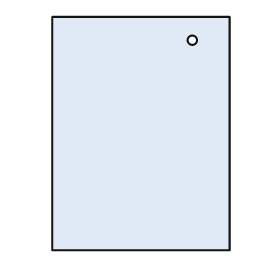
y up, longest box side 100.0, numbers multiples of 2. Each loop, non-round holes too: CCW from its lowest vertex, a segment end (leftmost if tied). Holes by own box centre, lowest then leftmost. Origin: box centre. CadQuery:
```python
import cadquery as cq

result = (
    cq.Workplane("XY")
    .moveTo(-38.0, -50.0)
    .lineTo(38.0, -50.0)
    .lineTo(38.0, 50.0)
    .lineTo(-38.0, 50.0)
    .close()
    .moveTo(22.0, 40.0)
    .circle(2.0)
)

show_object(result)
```